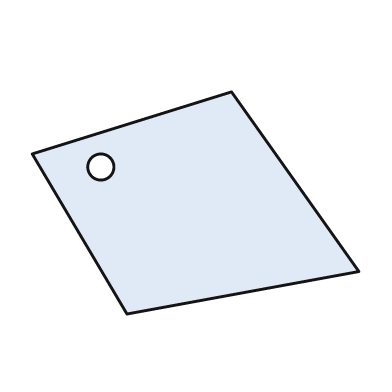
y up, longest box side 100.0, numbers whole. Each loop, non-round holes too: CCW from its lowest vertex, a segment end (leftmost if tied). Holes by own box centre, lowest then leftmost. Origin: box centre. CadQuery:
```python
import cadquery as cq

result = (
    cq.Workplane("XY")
    .moveTo(-21.0, -34.0)
    .lineTo(50.0, -21.0)
    .lineTo(11.0, 34.0)
    .lineTo(-50.0, 15.0)
    .close()
    .moveTo(-29.0, 11.0)
    .circle(4.0)
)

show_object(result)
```